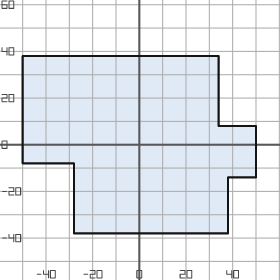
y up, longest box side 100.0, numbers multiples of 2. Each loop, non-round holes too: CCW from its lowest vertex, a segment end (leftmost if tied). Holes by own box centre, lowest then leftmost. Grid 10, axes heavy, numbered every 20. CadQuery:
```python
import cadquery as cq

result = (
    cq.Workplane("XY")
    .moveTo(-28.0, -38.0)
    .lineTo(38.0, -38.0)
    .lineTo(38.0, -14.0)
    .lineTo(50.0, -14.0)
    .lineTo(50.0, 8.0)
    .lineTo(34.0, 8.0)
    .lineTo(34.0, 38.0)
    .lineTo(-50.0, 38.0)
    .lineTo(-50.0, -8.0)
    .lineTo(-28.0, -8.0)
    .close()
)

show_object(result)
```